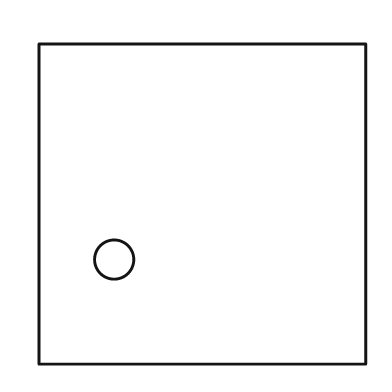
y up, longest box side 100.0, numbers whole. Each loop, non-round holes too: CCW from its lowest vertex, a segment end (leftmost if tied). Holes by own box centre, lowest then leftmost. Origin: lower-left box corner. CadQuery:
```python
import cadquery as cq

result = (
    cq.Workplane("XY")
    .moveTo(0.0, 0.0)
    .lineTo(100.0, 0.0)
    .lineTo(100.0, 98.0)
    .lineTo(0.0, 98.0)
    .close()
    .moveTo(23.0, 32.0)
    .circle(6.0)
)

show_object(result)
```